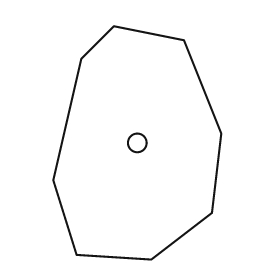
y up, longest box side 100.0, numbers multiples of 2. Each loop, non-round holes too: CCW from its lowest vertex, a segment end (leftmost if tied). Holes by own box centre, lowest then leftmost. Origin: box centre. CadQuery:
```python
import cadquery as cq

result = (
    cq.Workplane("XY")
    .moveTo(6.0, -50.0)
    .lineTo(32.0, -30.0)
    .lineTo(36.0, 4.0)
    .lineTo(20.0, 44.0)
    .lineTo(-10.0, 50.0)
    .lineTo(-24.0, 36.0)
    .lineTo(-36.0, -16.0)
    .lineTo(-26.0, -48.0)
    .close()
    .moveTo(0.0, 0.0)
    .circle(4.0)
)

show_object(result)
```